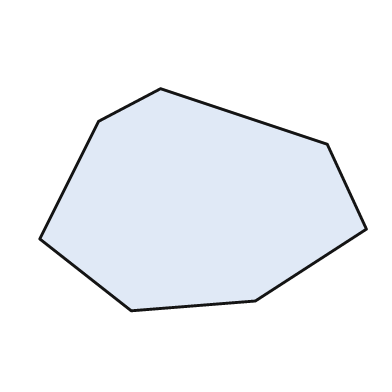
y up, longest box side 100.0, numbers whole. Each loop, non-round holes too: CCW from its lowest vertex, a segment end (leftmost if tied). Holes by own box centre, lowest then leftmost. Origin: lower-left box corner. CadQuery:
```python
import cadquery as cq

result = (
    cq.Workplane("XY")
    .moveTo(28.0, 0.0)
    .lineTo(66.0, 3.0)
    .lineTo(100.0, 25.0)
    .lineTo(88.0, 51.0)
    .lineTo(37.0, 68.0)
    .lineTo(18.0, 58.0)
    .lineTo(0.0, 22.0)
    .close()
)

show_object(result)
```